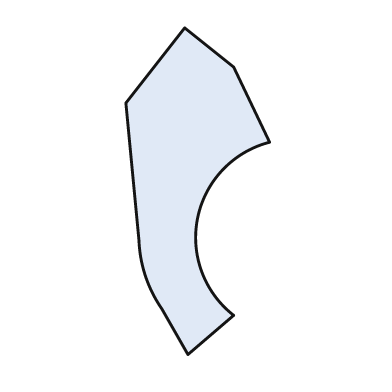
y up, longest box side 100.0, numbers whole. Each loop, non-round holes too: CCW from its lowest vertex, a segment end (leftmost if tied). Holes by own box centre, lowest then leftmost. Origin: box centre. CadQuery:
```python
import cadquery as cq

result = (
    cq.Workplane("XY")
    .moveTo(-3.0, -50.0)
    .lineTo(11.0, -38.0)
    .threePointArc((0.0, -8.0), (22.0, 15.0))
    .lineTo(11.0, 38.0)
    .lineTo(-4.0, 50.0)
    .lineTo(-22.0, 27.0)
    .lineTo(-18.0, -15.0)
    .threePointArc((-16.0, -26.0), (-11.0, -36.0))
    .close()
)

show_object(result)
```